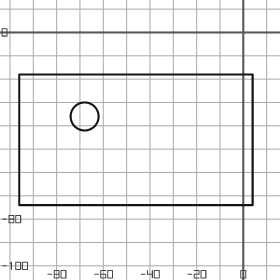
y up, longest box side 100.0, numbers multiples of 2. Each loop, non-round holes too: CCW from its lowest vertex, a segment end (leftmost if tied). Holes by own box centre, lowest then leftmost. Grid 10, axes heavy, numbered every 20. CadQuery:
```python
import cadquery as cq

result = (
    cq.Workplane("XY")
    .moveTo(-96.0, -74.0)
    .lineTo(4.0, -74.0)
    .lineTo(4.0, -18.0)
    .lineTo(-96.0, -18.0)
    .close()
    .moveTo(-68.0, -36.0)
    .circle(6.0)
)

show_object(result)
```